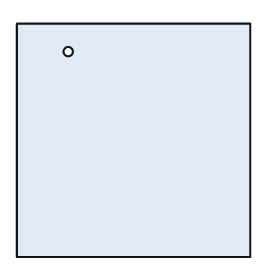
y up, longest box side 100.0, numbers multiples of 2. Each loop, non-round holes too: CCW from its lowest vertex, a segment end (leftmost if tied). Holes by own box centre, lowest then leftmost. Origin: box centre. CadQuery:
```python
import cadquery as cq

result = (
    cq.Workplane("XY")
    .moveTo(-50.0, -50.0)
    .lineTo(50.0, -50.0)
    .lineTo(50.0, 50.0)
    .lineTo(-50.0, 50.0)
    .close()
    .moveTo(-28.0, 38.0)
    .circle(2.0)
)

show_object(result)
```